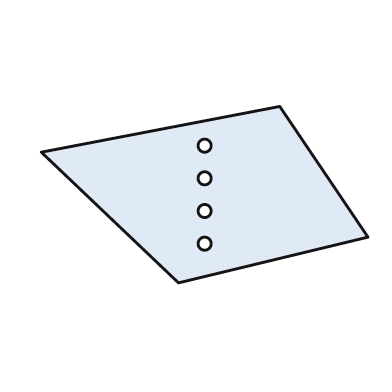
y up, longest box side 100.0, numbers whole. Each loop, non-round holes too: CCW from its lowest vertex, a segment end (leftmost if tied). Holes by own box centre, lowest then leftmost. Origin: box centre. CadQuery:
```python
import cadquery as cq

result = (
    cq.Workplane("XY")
    .moveTo(-8.0, -27.0)
    .lineTo(50.0, -13.0)
    .lineTo(23.0, 27.0)
    .lineTo(-50.0, 13.0)
    .close()
    .moveTo(0.0, -15.0)
    .circle(2.0)
    .moveTo(0.0, -5.0)
    .circle(2.0)
    .moveTo(0.0, 5.0)
    .circle(2.0)
    .moveTo(0.0, 15.0)
    .circle(2.0)
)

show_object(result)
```